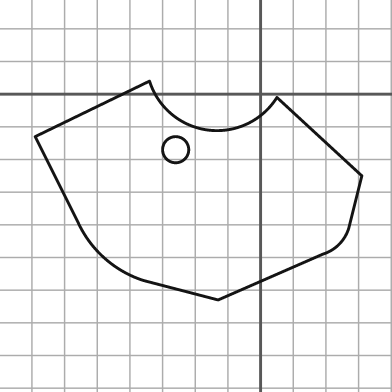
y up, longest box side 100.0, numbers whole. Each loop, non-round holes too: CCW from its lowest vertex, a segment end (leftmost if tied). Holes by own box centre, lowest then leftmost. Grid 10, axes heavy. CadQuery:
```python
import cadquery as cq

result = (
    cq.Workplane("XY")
    .moveTo(-13.0, -63.0)
    .lineTo(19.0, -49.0)
    .threePointArc((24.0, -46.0), (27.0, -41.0))
    .lineTo(31.0, -25.0)
    .lineTo(5.0, -1.0)
    .threePointArc((-16.0, -11.0), (-34.0, 4.0))
    .lineTo(-69.0, -13.0)
    .lineTo(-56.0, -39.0)
    .threePointArc((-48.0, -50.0), (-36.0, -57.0))
    .close()
    .moveTo(-26.0, -17.0)
    .circle(4.0)
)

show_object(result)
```